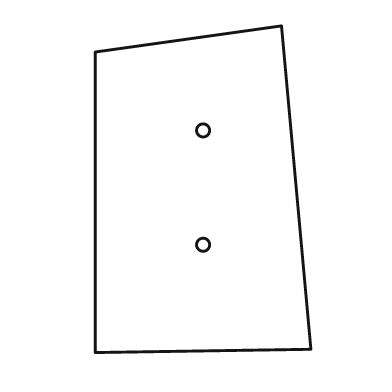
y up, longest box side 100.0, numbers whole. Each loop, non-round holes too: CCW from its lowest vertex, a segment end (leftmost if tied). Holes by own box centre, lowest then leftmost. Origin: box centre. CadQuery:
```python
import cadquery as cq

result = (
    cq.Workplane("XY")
    .moveTo(-33.0, -50.0)
    .lineTo(33.0, -49.0)
    .lineTo(24.0, 50.0)
    .lineTo(-33.0, 42.0)
    .close()
    .moveTo(0.0, -17.0)
    .circle(2.0)
    .moveTo(0.0, 18.0)
    .circle(2.0)
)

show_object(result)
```